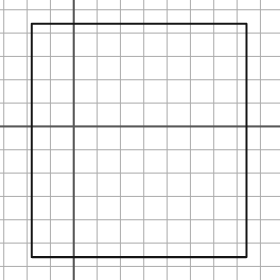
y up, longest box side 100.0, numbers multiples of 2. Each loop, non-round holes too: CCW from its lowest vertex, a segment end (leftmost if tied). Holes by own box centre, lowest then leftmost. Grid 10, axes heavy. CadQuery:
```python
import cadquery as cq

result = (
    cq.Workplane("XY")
    .moveTo(-18.0, -56.0)
    .lineTo(74.0, -56.0)
    .lineTo(74.0, 44.0)
    .lineTo(-18.0, 44.0)
    .close()
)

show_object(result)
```